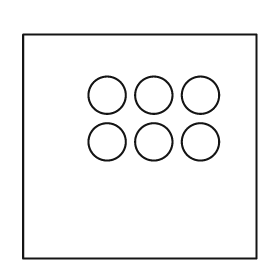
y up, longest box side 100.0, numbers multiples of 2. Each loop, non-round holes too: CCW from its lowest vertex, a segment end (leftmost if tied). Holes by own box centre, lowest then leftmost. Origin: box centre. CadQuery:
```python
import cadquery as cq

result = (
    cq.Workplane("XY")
    .moveTo(-50.0, -48.0)
    .lineTo(50.0, -48.0)
    .lineTo(50.0, 48.0)
    .lineTo(-50.0, 48.0)
    .close()
    .moveTo(-14.0, 2.0)
    .circle(8.0)
    .moveTo(6.0, 2.0)
    .circle(8.0)
    .moveTo(26.0, 2.0)
    .circle(8.0)
    .moveTo(-14.0, 22.0)
    .circle(8.0)
    .moveTo(6.0, 22.0)
    .circle(8.0)
    .moveTo(26.0, 22.0)
    .circle(8.0)
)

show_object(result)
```